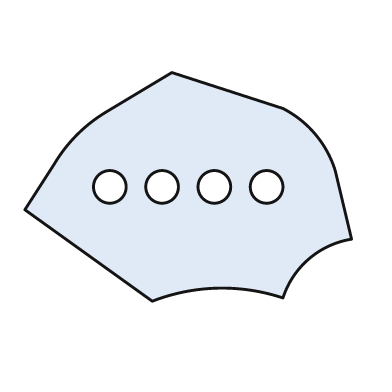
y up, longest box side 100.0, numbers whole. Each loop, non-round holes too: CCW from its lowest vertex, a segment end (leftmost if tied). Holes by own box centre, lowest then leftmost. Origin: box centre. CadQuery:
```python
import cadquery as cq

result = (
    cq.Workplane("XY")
    .moveTo(-11.0, -35.0)
    .threePointArc((9.0, -31.0), (29.0, -34.0))
    .threePointArc((37.0, -22.0), (50.0, -16.0))
    .lineTo(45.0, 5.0)
    .threePointArc((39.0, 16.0), (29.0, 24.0))
    .lineTo(-5.0, 35.0)
    .lineTo(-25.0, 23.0)
    .threePointArc((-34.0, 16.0), (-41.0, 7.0))
    .lineTo(-50.0, -7.0)
    .close()
    .moveTo(-24.0, 0.0)
    .circle(5.0)
    .moveTo(-8.0, 0.0)
    .circle(5.0)
    .moveTo(8.0, 0.0)
    .circle(5.0)
    .moveTo(24.0, 0.0)
    .circle(5.0)
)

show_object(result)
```